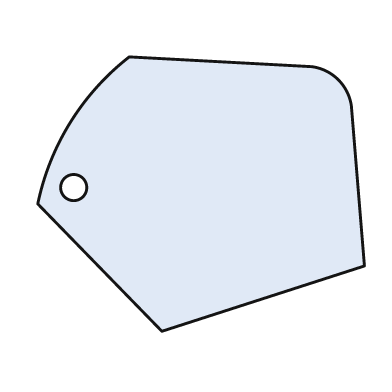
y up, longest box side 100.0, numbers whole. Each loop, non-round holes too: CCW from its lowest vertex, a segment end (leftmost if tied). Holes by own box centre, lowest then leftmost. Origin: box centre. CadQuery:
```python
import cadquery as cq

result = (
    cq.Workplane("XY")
    .moveTo(-12.0, -42.0)
    .lineTo(50.0, -22.0)
    .lineTo(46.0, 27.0)
    .threePointArc((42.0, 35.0), (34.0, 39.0))
    .lineTo(-22.0, 42.0)
    .threePointArc((-40.0, 22.0), (-50.0, -3.0))
    .close()
    .moveTo(-39.0, 2.0)
    .circle(4.0)
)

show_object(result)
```